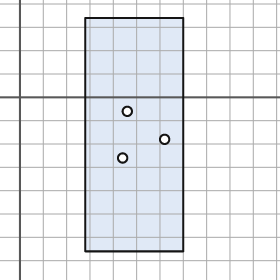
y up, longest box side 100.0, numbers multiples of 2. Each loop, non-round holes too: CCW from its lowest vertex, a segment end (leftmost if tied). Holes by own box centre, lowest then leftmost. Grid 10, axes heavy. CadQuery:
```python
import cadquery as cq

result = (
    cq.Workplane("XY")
    .moveTo(28.0, -66.0)
    .lineTo(70.0, -66.0)
    .lineTo(70.0, 34.0)
    .lineTo(28.0, 34.0)
    .close()
    .moveTo(44.0, -26.0)
    .circle(2.0)
    .moveTo(62.0, -18.0)
    .circle(2.0)
    .moveTo(46.0, -6.0)
    .circle(2.0)
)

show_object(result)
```